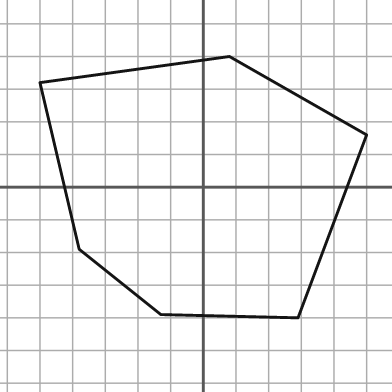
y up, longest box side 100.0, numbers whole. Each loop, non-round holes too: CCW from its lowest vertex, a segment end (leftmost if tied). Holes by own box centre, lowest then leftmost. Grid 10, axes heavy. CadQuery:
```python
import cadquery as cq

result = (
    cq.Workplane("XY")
    .moveTo(29.0, -40.0)
    .lineTo(50.0, 16.0)
    .lineTo(8.0, 40.0)
    .lineTo(-50.0, 32.0)
    .lineTo(-38.0, -19.0)
    .lineTo(-13.0, -39.0)
    .close()
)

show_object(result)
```